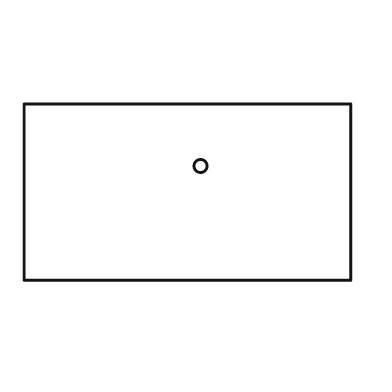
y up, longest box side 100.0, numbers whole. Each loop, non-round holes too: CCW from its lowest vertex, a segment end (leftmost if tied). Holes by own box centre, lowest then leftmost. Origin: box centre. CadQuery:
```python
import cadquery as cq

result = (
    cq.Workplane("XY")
    .moveTo(-50.0, -27.0)
    .lineTo(50.0, -27.0)
    .lineTo(50.0, 27.0)
    .lineTo(-50.0, 27.0)
    .close()
    .moveTo(4.0, 8.0)
    .circle(2.0)
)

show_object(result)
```